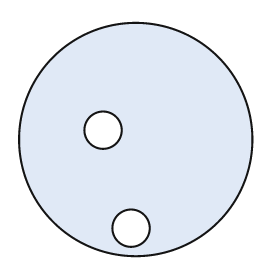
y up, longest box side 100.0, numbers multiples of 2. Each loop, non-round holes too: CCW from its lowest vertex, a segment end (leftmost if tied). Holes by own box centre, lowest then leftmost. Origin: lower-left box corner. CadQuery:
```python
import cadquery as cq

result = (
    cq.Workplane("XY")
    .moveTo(50.0, 50.0)
    .circle(50.0)
    .moveTo(48.0, 12.0)
    .circle(8.0)
    .moveTo(36.0, 54.0)
    .circle(8.0)
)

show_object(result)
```